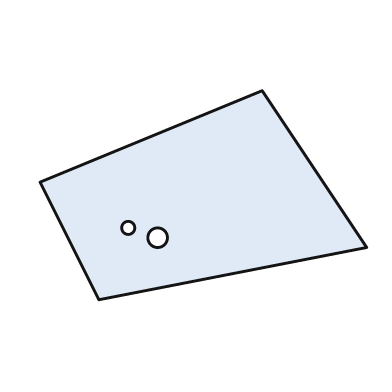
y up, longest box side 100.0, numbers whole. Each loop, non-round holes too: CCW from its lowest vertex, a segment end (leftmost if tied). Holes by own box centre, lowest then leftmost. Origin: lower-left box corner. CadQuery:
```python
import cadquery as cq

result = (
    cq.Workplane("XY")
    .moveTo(18.0, 0.0)
    .lineTo(100.0, 16.0)
    .lineTo(68.0, 64.0)
    .lineTo(0.0, 36.0)
    .close()
    .moveTo(36.0, 19.0)
    .circle(3.0)
    .moveTo(27.0, 22.0)
    .circle(2.0)
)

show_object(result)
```